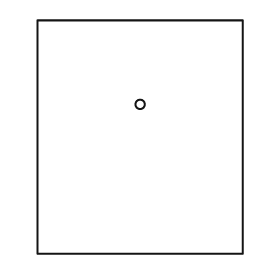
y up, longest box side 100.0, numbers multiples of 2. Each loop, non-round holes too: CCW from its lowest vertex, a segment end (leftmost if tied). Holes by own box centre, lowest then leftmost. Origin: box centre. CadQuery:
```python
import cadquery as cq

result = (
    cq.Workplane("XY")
    .moveTo(-44.0, -50.0)
    .lineTo(44.0, -50.0)
    .lineTo(44.0, 50.0)
    .lineTo(-44.0, 50.0)
    .close()
    .moveTo(0.0, 14.0)
    .circle(2.0)
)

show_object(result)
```